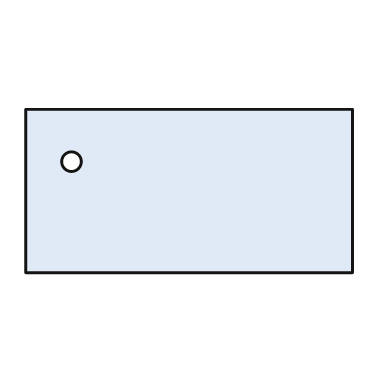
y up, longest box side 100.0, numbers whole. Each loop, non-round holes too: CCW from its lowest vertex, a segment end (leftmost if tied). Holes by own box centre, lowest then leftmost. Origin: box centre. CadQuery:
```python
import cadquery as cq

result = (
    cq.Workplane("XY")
    .moveTo(-50.0, -25.0)
    .lineTo(50.0, -25.0)
    .lineTo(50.0, 25.0)
    .lineTo(-50.0, 25.0)
    .close()
    .moveTo(-36.0, 9.0)
    .circle(3.0)
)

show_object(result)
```